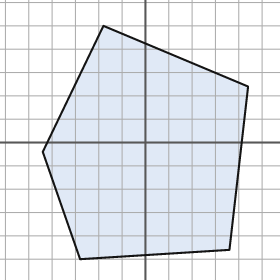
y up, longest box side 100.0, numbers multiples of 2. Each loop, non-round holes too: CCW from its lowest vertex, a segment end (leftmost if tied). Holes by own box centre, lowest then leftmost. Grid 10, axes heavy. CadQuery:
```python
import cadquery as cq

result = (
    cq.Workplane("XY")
    .moveTo(-28.0, -50.0)
    .lineTo(36.0, -46.0)
    .lineTo(44.0, 24.0)
    .lineTo(-18.0, 50.0)
    .lineTo(-44.0, -4.0)
    .close()
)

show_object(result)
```